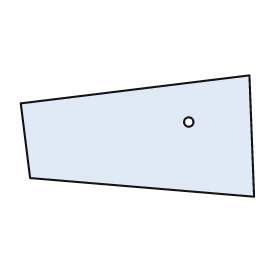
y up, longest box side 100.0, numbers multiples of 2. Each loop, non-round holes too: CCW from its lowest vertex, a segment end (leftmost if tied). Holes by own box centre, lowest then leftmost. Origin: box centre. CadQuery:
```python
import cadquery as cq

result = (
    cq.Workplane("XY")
    .moveTo(50.0, -26.0)
    .lineTo(48.0, 26.0)
    .lineTo(-50.0, 14.0)
    .lineTo(-46.0, -18.0)
    .close()
    .moveTo(22.0, 6.0)
    .circle(2.0)
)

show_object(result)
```